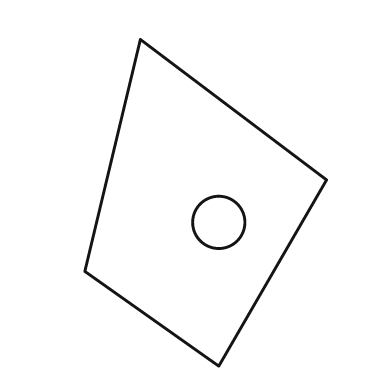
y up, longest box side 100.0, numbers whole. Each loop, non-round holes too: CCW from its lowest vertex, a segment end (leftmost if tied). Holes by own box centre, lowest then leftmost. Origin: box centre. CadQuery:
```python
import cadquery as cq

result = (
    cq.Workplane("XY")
    .moveTo(4.0, -50.0)
    .lineTo(37.0, 7.0)
    .lineTo(-20.0, 50.0)
    .lineTo(-37.0, -21.0)
    .close()
    .moveTo(4.0, -6.0)
    .circle(8.0)
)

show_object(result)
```